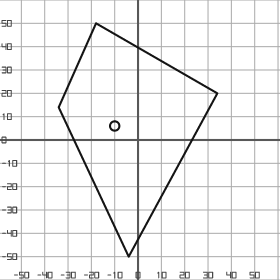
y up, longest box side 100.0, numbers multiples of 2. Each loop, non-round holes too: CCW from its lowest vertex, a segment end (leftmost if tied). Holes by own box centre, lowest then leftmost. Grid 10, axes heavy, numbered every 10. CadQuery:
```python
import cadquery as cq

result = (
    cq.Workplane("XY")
    .moveTo(-4.0, -50.0)
    .lineTo(34.0, 20.0)
    .lineTo(-18.0, 50.0)
    .lineTo(-34.0, 14.0)
    .close()
    .moveTo(-10.0, 6.0)
    .circle(2.0)
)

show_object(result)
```